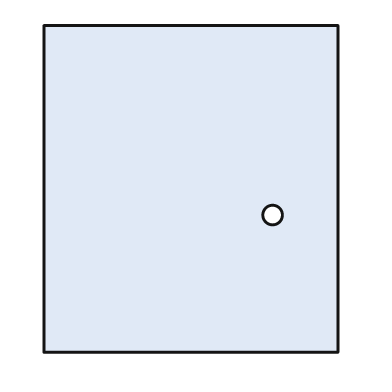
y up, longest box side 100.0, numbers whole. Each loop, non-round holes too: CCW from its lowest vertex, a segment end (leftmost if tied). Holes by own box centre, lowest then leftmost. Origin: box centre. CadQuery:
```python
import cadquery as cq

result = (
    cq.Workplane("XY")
    .moveTo(-45.0, -50.0)
    .lineTo(45.0, -50.0)
    .lineTo(45.0, 50.0)
    .lineTo(-45.0, 50.0)
    .close()
    .moveTo(25.0, -8.0)
    .circle(3.0)
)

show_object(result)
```